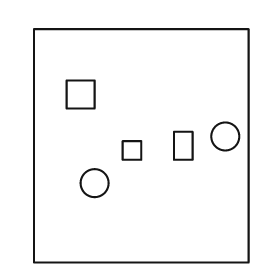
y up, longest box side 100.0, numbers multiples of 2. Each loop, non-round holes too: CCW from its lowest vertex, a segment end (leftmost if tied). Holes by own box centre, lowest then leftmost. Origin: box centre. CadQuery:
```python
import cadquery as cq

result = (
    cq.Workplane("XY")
    .moveTo(-46.0, -50.0)
    .lineTo(46.0, -50.0)
    .lineTo(46.0, 50.0)
    .lineTo(-46.0, 50.0)
    .close()
    .moveTo(-20.0, -16.0)
    .circle(6.0)
    .moveTo(-8.0, -6.0)
    .lineTo(0.0, -6.0)
    .lineTo(0.0, 2.0)
    .lineTo(-8.0, 2.0)
    .close()
    .moveTo(14.0, -6.0)
    .lineTo(22.0, -6.0)
    .lineTo(22.0, 6.0)
    .lineTo(14.0, 6.0)
    .close()
    .moveTo(36.0, 4.0)
    .circle(6.0)
    .moveTo(-32.0, 16.0)
    .lineTo(-20.0, 16.0)
    .lineTo(-20.0, 28.0)
    .lineTo(-32.0, 28.0)
    .close()
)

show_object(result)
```